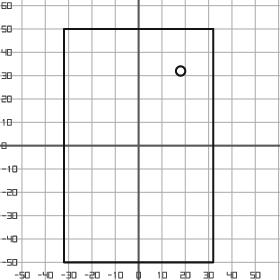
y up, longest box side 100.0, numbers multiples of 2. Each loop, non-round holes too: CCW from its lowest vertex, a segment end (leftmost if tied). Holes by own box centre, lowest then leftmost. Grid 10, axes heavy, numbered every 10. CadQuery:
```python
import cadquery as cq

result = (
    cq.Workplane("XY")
    .moveTo(-32.0, -50.0)
    .lineTo(32.0, -50.0)
    .lineTo(32.0, 50.0)
    .lineTo(-32.0, 50.0)
    .close()
    .moveTo(18.0, 32.0)
    .circle(2.0)
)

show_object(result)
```